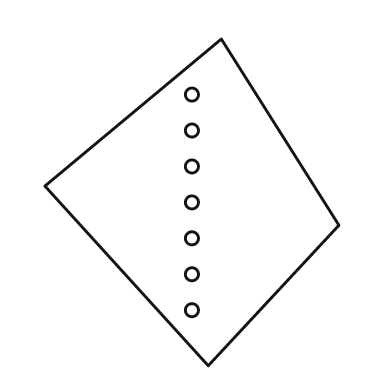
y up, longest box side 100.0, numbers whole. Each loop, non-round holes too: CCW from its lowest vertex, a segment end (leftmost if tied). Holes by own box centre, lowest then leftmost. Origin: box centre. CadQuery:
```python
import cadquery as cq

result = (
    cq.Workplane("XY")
    .moveTo(5.0, -50.0)
    .lineTo(45.0, -7.0)
    .lineTo(9.0, 50.0)
    .lineTo(-45.0, 5.0)
    .close()
    .moveTo(0.0, -33.0)
    .circle(2.0)
    .moveTo(0.0, -22.0)
    .circle(2.0)
    .moveTo(0.0, -11.0)
    .circle(2.0)
    .moveTo(0.0, 0.0)
    .circle(2.0)
    .moveTo(0.0, 11.0)
    .circle(2.0)
    .moveTo(0.0, 22.0)
    .circle(2.0)
    .moveTo(0.0, 33.0)
    .circle(2.0)
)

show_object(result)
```